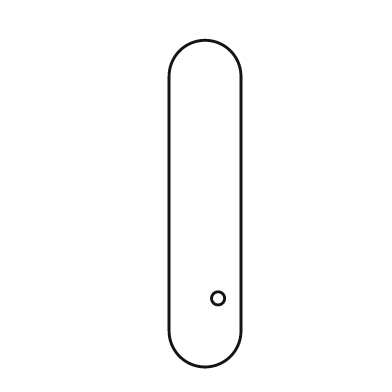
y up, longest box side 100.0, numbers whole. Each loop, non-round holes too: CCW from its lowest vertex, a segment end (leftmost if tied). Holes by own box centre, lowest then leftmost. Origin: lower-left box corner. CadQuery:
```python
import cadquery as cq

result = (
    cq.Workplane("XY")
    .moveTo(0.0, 11.0)
    .threePointArc((11.0, 0.0), (22.0, 11.0))
    .lineTo(22.0, 89.0)
    .threePointArc((11.0, 100.0), (0.0, 89.0))
    .close()
    .moveTo(15.0, 21.0)
    .circle(2.0)
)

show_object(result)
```